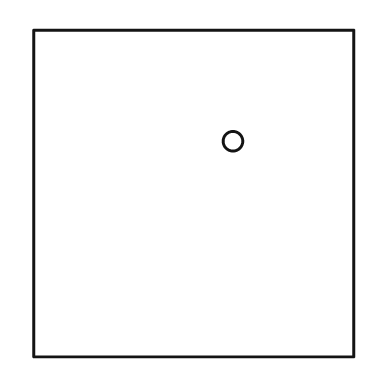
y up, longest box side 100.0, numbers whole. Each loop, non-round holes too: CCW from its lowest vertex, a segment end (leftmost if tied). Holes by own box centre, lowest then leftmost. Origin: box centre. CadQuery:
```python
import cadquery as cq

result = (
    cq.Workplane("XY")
    .moveTo(-49.0, -50.0)
    .lineTo(49.0, -50.0)
    .lineTo(49.0, 50.0)
    .lineTo(-49.0, 50.0)
    .close()
    .moveTo(12.0, 16.0)
    .circle(3.0)
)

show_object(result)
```